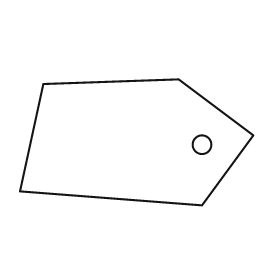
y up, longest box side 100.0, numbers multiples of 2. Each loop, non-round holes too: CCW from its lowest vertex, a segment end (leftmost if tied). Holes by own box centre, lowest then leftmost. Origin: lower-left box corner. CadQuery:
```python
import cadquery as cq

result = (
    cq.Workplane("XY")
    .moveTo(78.0, 0.0)
    .lineTo(100.0, 30.0)
    .lineTo(68.0, 54.0)
    .lineTo(10.0, 52.0)
    .lineTo(0.0, 6.0)
    .close()
    .moveTo(78.0, 26.0)
    .circle(4.0)
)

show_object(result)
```